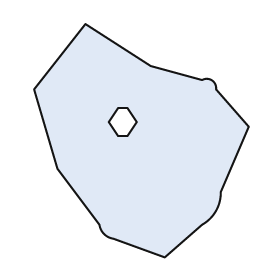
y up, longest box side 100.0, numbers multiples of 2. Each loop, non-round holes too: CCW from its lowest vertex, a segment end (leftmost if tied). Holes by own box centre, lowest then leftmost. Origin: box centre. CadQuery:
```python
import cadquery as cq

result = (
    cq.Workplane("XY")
    .moveTo(10.0, -50.0)
    .lineTo(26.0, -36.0)
    .threePointArc((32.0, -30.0), (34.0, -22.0))
    .lineTo(46.0, 6.0)
    .lineTo(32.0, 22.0)
    .threePointArc((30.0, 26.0), (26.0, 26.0))
    .lineTo(4.0, 32.0)
    .lineTo(-24.0, 50.0)
    .lineTo(-46.0, 22.0)
    .lineTo(-36.0, -12.0)
    .lineTo(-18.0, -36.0)
    .threePointArc((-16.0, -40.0), (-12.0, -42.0))
    .close()
    .moveTo(-10.0, 2.0)
    .lineTo(-6.0, 2.0)
    .lineTo(-2.0, 8.0)
    .lineTo(-6.0, 14.0)
    .lineTo(-10.0, 14.0)
    .lineTo(-14.0, 8.0)
    .close()
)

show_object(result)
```